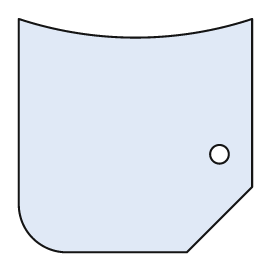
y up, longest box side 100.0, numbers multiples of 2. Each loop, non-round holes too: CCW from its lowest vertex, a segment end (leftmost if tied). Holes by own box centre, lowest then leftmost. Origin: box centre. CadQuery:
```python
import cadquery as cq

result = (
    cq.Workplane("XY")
    .moveTo(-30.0, -50.0)
    .lineTo(22.0, -50.0)
    .lineTo(50.0, -22.0)
    .lineTo(50.0, 50.0)
    .threePointArc((0.0, 42.0), (-50.0, 50.0))
    .lineTo(-50.0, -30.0)
    .threePointArc((-44.0, -44.0), (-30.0, -50.0))
    .close()
    .moveTo(36.0, -8.0)
    .circle(4.0)
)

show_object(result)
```